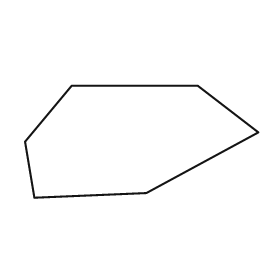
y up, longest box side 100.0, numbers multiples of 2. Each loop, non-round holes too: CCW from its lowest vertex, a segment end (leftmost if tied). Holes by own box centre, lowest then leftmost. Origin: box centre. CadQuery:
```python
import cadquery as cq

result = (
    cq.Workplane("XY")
    .moveTo(-46.0, -24.0)
    .lineTo(2.0, -22.0)
    .lineTo(50.0, 4.0)
    .lineTo(24.0, 24.0)
    .lineTo(-30.0, 24.0)
    .lineTo(-50.0, 0.0)
    .close()
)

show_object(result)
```